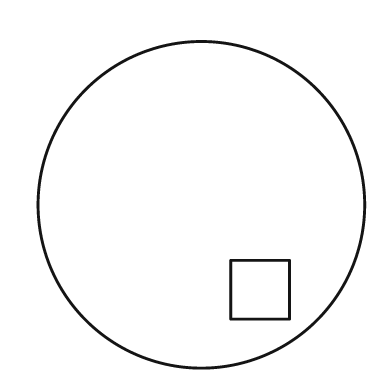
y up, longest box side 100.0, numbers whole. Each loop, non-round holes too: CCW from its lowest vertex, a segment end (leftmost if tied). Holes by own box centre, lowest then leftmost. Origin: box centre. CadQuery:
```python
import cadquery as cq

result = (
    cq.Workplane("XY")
    .moveTo(0.0, 0.0)
    .circle(50.0)
    .moveTo(9.0, -35.0)
    .lineTo(27.0, -35.0)
    .lineTo(27.0, -17.0)
    .lineTo(9.0, -17.0)
    .close()
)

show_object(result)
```